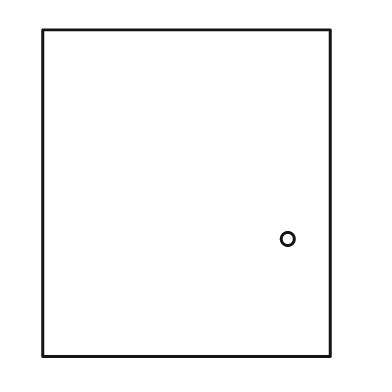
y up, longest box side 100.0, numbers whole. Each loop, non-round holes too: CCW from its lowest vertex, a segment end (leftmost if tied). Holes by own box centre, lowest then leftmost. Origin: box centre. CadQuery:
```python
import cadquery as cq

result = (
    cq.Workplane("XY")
    .moveTo(-44.0, -50.0)
    .lineTo(44.0, -50.0)
    .lineTo(44.0, 50.0)
    .lineTo(-44.0, 50.0)
    .close()
    .moveTo(31.0, -14.0)
    .circle(2.0)
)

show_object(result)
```